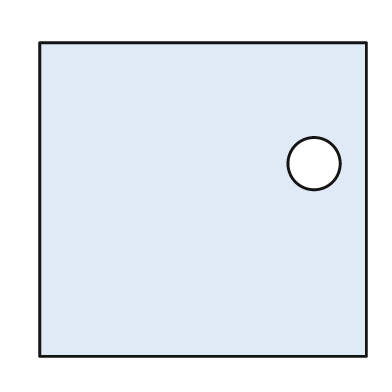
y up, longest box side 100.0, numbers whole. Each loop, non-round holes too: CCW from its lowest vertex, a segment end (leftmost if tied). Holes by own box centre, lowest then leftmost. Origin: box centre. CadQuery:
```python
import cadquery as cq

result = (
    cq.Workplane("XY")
    .moveTo(-50.0, -48.0)
    .lineTo(50.0, -48.0)
    .lineTo(50.0, 48.0)
    .lineTo(-50.0, 48.0)
    .close()
    .moveTo(34.0, 11.0)
    .circle(8.0)
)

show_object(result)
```